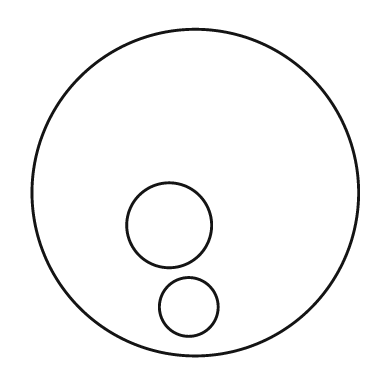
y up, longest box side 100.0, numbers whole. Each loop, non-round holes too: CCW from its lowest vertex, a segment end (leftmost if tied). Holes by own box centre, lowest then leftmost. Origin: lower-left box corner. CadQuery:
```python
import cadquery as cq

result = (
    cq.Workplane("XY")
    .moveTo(50.0, 50.0)
    .circle(50.0)
    .moveTo(48.0, 15.0)
    .circle(9.0)
    .moveTo(42.0, 40.0)
    .circle(13.0)
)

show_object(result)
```